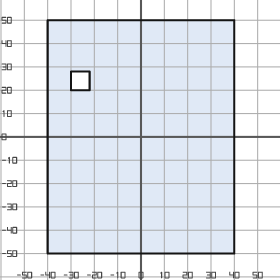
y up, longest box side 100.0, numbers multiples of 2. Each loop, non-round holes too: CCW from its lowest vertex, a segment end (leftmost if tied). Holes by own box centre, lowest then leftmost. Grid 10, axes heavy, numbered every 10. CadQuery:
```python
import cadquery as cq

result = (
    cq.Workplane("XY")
    .moveTo(-40.0, -50.0)
    .lineTo(40.0, -50.0)
    .lineTo(40.0, 50.0)
    .lineTo(-40.0, 50.0)
    .close()
    .moveTo(-30.0, 20.0)
    .lineTo(-22.0, 20.0)
    .lineTo(-22.0, 28.0)
    .lineTo(-30.0, 28.0)
    .close()
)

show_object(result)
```